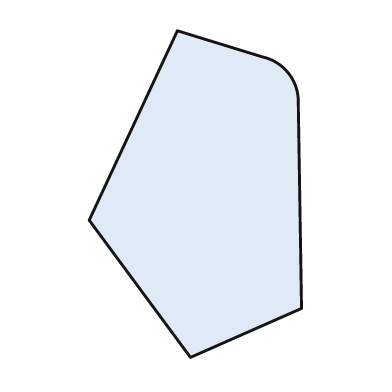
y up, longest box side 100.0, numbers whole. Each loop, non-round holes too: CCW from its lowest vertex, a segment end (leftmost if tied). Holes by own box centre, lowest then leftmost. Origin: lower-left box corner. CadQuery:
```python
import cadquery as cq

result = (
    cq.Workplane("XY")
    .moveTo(31.0, 0.0)
    .lineTo(65.0, 15.0)
    .lineTo(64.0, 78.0)
    .threePointArc((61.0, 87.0), (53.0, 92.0))
    .lineTo(27.0, 100.0)
    .lineTo(0.0, 42.0)
    .close()
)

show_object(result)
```